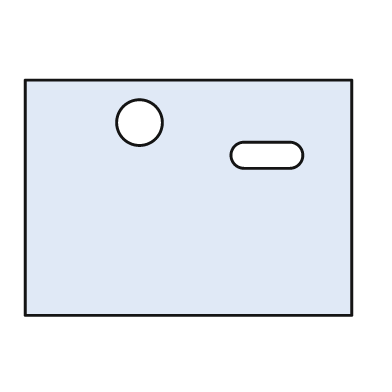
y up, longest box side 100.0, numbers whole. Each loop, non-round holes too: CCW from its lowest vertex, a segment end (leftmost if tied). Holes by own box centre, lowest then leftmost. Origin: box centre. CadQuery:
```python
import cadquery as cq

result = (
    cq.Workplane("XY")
    .moveTo(-50.0, -36.0)
    .lineTo(50.0, -36.0)
    .lineTo(50.0, 36.0)
    .lineTo(-50.0, 36.0)
    .close()
    .moveTo(17.0, 9.0)
    .lineTo(31.0, 9.0)
    .threePointArc((35.0, 13.0), (31.0, 17.0))
    .lineTo(17.0, 17.0)
    .threePointArc((13.0, 13.0), (17.0, 9.0))
    .close()
    .moveTo(-15.0, 23.0)
    .circle(7.0)
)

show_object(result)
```